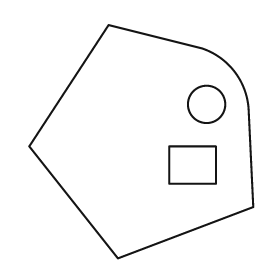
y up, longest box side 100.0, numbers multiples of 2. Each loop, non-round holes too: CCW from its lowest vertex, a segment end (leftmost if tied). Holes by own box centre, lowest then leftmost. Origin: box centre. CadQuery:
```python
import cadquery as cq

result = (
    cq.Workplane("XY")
    .moveTo(-10.0, -50.0)
    .lineTo(48.0, -28.0)
    .lineTo(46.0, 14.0)
    .threePointArc((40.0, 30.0), (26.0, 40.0))
    .lineTo(-14.0, 50.0)
    .lineTo(-48.0, -2.0)
    .close()
    .moveTo(12.0, -18.0)
    .lineTo(32.0, -18.0)
    .lineTo(32.0, -2.0)
    .lineTo(12.0, -2.0)
    .close()
    .moveTo(28.0, 16.0)
    .circle(8.0)
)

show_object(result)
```